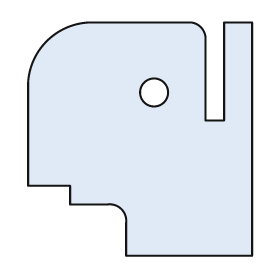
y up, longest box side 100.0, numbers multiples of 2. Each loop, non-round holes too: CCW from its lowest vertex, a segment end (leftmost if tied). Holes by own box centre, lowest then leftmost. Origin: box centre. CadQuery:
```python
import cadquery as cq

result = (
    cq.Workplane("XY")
    .moveTo(-6.0, -50.0)
    .lineTo(48.0, -50.0)
    .lineTo(48.0, 50.0)
    .lineTo(36.0, 50.0)
    .lineTo(36.0, 8.0)
    .lineTo(28.0, 8.0)
    .lineTo(28.0, 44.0)
    .threePointArc((26.0, 48.0), (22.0, 50.0))
    .lineTo(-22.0, 50.0)
    .threePointArc((-40.0, 42.0), (-48.0, 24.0))
    .lineTo(-48.0, -20.0)
    .lineTo(-30.0, -20.0)
    .lineTo(-30.0, -28.0)
    .lineTo(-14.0, -28.0)
    .threePointArc((-8.0, -30.0), (-6.0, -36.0))
    .close()
    .moveTo(6.0, 20.0)
    .circle(6.0)
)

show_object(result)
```